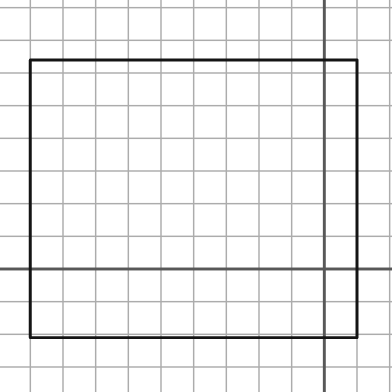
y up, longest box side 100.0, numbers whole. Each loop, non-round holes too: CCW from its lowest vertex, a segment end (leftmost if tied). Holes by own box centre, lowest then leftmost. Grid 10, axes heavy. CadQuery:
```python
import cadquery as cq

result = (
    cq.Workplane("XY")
    .moveTo(-90.0, -21.0)
    .lineTo(10.0, -21.0)
    .lineTo(10.0, 64.0)
    .lineTo(-90.0, 64.0)
    .close()
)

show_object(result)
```